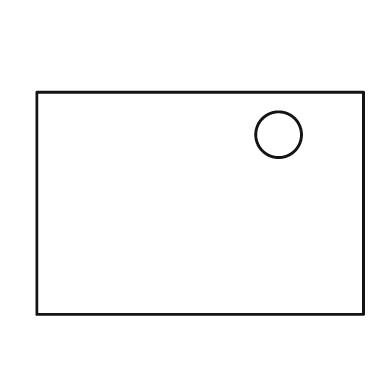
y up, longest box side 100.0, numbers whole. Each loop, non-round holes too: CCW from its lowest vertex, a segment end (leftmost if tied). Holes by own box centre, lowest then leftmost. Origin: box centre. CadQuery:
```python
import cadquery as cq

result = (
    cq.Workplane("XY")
    .moveTo(-50.0, -34.0)
    .lineTo(50.0, -34.0)
    .lineTo(50.0, 34.0)
    .lineTo(-50.0, 34.0)
    .close()
    .moveTo(24.0, 21.0)
    .circle(7.0)
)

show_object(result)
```